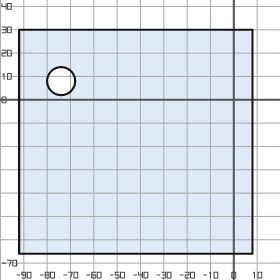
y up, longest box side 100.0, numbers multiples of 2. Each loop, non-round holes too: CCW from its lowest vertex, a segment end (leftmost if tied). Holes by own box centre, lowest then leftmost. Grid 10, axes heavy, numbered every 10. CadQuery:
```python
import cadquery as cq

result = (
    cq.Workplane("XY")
    .moveTo(-92.0, -66.0)
    .lineTo(8.0, -66.0)
    .lineTo(8.0, 30.0)
    .lineTo(-92.0, 30.0)
    .close()
    .moveTo(-74.0, 8.0)
    .circle(6.0)
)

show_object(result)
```